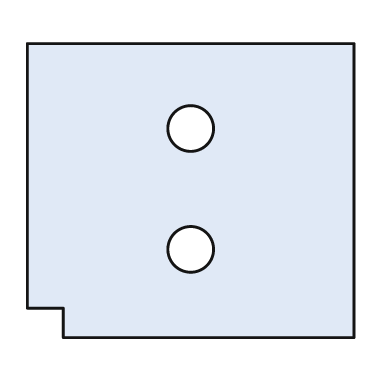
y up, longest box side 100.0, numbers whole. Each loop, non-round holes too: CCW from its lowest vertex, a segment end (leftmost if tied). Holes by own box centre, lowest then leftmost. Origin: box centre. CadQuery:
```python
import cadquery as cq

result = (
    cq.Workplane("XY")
    .moveTo(-39.0, -45.0)
    .lineTo(50.0, -45.0)
    .lineTo(50.0, 45.0)
    .lineTo(-50.0, 45.0)
    .lineTo(-50.0, -36.0)
    .lineTo(-39.0, -36.0)
    .close()
    .moveTo(0.0, -18.0)
    .circle(7.0)
    .moveTo(0.0, 19.0)
    .circle(7.0)
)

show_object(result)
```